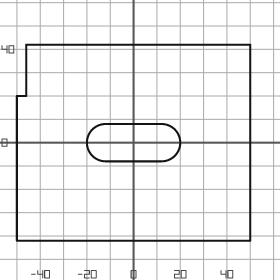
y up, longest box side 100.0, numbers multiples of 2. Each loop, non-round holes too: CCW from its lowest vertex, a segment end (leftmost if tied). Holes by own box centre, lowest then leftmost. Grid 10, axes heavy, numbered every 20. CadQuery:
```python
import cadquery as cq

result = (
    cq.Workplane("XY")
    .moveTo(-50.0, -42.0)
    .lineTo(50.0, -42.0)
    .lineTo(50.0, 42.0)
    .lineTo(-46.0, 42.0)
    .lineTo(-46.0, 20.0)
    .lineTo(-50.0, 20.0)
    .close()
    .moveTo(-12.0, -8.0)
    .lineTo(12.0, -8.0)
    .threePointArc((20.0, 0.0), (12.0, 8.0))
    .lineTo(-12.0, 8.0)
    .threePointArc((-20.0, 0.0), (-12.0, -8.0))
    .close()
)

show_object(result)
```